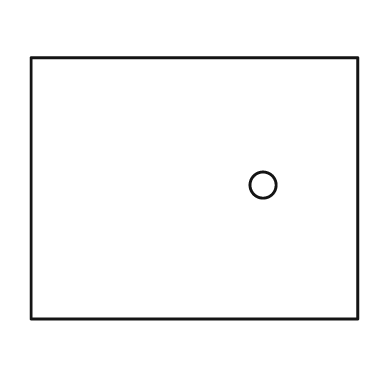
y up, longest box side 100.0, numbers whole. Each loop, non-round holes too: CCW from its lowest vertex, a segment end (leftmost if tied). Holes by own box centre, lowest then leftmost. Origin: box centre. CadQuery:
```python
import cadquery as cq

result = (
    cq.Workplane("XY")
    .moveTo(-50.0, -40.0)
    .lineTo(50.0, -40.0)
    .lineTo(50.0, 40.0)
    .lineTo(-50.0, 40.0)
    .close()
    .moveTo(21.0, 1.0)
    .circle(4.0)
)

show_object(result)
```